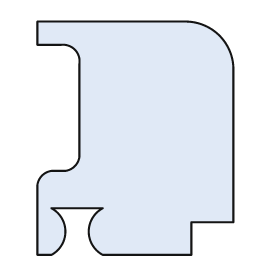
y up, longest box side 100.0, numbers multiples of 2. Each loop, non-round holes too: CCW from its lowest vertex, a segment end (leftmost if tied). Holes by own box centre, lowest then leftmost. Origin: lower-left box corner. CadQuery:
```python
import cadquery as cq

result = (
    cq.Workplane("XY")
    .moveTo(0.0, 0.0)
    .lineTo(6.0, 0.0)
    .threePointArc((12.0, 10.0), (6.0, 20.0))
    .lineTo(28.0, 20.0)
    .threePointArc((22.0, 10.0), (28.0, 0.0))
    .lineTo(66.0, 0.0)
    .lineTo(66.0, 14.0)
    .lineTo(84.0, 14.0)
    .lineTo(84.0, 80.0)
    .threePointArc((78.0, 94.0), (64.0, 100.0))
    .lineTo(0.0, 100.0)
    .lineTo(0.0, 90.0)
    .lineTo(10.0, 90.0)
    .threePointArc((16.0, 88.0), (18.0, 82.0))
    .lineTo(18.0, 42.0)
    .threePointArc((16.0, 38.0), (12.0, 36.0))
    .lineTo(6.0, 36.0)
    .threePointArc((2.0, 34.0), (0.0, 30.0))
    .close()
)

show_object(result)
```